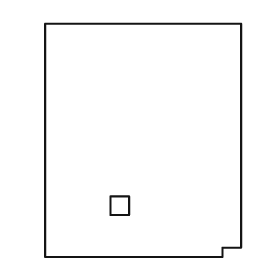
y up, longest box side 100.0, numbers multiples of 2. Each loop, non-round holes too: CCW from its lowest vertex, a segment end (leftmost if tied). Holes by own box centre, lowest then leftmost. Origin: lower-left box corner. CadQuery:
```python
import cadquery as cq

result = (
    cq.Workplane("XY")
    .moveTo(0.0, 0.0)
    .lineTo(76.0, 0.0)
    .lineTo(76.0, 4.0)
    .lineTo(84.0, 4.0)
    .lineTo(84.0, 100.0)
    .lineTo(0.0, 100.0)
    .close()
    .moveTo(28.0, 18.0)
    .lineTo(36.0, 18.0)
    .lineTo(36.0, 26.0)
    .lineTo(28.0, 26.0)
    .close()
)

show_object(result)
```